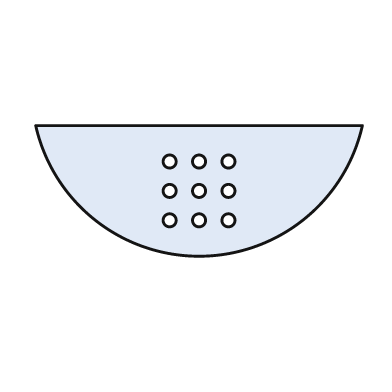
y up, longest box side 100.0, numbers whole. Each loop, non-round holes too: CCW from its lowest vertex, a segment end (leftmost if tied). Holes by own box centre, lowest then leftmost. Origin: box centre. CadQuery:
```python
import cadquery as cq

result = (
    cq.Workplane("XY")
    .moveTo(-50.0, 20.0)
    .threePointArc((0.0, -20.0), (50.0, 20.0))
    .close()
    .moveTo(-9.0, -9.0)
    .circle(2.0)
    .moveTo(0.0, -9.0)
    .circle(2.0)
    .moveTo(9.0, -9.0)
    .circle(2.0)
    .moveTo(-9.0, 0.0)
    .circle(2.0)
    .moveTo(0.0, 0.0)
    .circle(2.0)
    .moveTo(9.0, 0.0)
    .circle(2.0)
    .moveTo(-9.0, 9.0)
    .circle(2.0)
    .moveTo(0.0, 9.0)
    .circle(2.0)
    .moveTo(9.0, 9.0)
    .circle(2.0)
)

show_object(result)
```